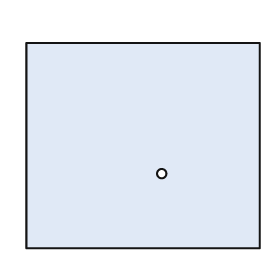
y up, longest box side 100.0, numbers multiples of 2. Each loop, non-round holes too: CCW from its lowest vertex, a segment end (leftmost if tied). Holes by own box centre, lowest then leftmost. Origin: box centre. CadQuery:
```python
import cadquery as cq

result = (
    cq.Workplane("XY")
    .moveTo(-50.0, -44.0)
    .lineTo(50.0, -44.0)
    .lineTo(50.0, 44.0)
    .lineTo(-50.0, 44.0)
    .close()
    .moveTo(8.0, -12.0)
    .circle(2.0)
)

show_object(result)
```